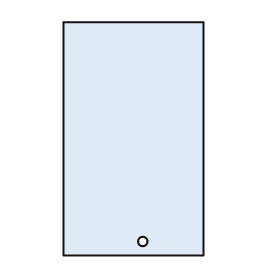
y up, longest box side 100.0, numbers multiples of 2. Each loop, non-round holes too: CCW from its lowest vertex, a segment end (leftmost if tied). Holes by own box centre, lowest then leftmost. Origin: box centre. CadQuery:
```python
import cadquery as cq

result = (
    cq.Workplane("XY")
    .moveTo(-30.0, -50.0)
    .lineTo(30.0, -50.0)
    .lineTo(30.0, 50.0)
    .lineTo(-30.0, 50.0)
    .close()
    .moveTo(4.0, -44.0)
    .circle(2.0)
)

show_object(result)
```